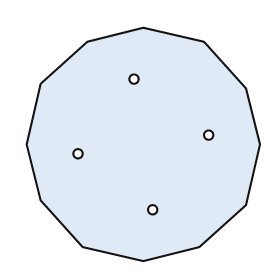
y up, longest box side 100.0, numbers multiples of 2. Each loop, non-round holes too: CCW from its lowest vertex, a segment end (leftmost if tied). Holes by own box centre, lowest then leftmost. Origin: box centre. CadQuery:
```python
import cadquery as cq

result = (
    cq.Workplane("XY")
    .moveTo(0.0, -50.0)
    .lineTo(24.0, -44.0)
    .lineTo(44.0, -26.0)
    .lineTo(50.0, 0.0)
    .lineTo(44.0, 24.0)
    .lineTo(26.0, 44.0)
    .lineTo(0.0, 50.0)
    .lineTo(-24.0, 44.0)
    .lineTo(-44.0, 26.0)
    .lineTo(-50.0, 0.0)
    .lineTo(-44.0, -24.0)
    .lineTo(-26.0, -44.0)
    .close()
    .moveTo(4.0, -28.0)
    .circle(2.0)
    .moveTo(-28.0, -4.0)
    .circle(2.0)
    .moveTo(28.0, 4.0)
    .circle(2.0)
    .moveTo(-4.0, 28.0)
    .circle(2.0)
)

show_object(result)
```